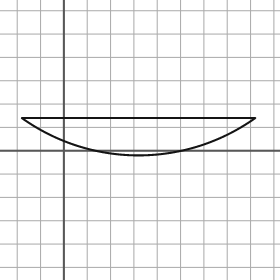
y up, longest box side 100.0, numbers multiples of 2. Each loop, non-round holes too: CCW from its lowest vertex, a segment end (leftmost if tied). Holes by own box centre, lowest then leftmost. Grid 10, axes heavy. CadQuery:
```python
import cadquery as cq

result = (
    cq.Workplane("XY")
    .moveTo(-18.0, 14.0)
    .threePointArc((32.0, -2.0), (82.0, 14.0))
    .close()
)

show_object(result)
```